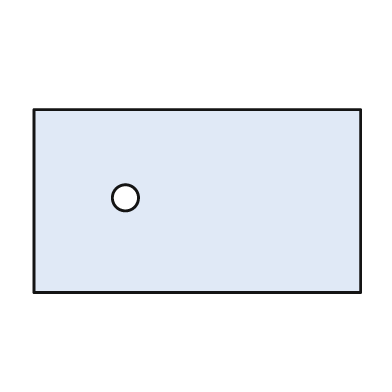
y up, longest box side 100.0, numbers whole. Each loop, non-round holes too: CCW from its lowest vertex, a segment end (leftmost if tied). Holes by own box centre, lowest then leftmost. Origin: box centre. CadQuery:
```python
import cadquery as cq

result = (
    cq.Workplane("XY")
    .moveTo(-50.0, -28.0)
    .lineTo(50.0, -28.0)
    .lineTo(50.0, 28.0)
    .lineTo(-50.0, 28.0)
    .close()
    .moveTo(-22.0, 1.0)
    .circle(4.0)
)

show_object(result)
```